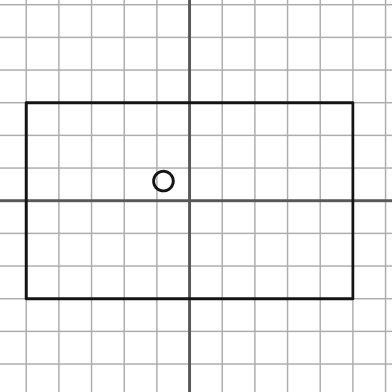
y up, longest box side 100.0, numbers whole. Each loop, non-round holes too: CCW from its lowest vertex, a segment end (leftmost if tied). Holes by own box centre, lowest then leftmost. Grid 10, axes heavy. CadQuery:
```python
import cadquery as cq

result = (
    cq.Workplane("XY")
    .moveTo(-50.0, -30.0)
    .lineTo(50.0, -30.0)
    .lineTo(50.0, 30.0)
    .lineTo(-50.0, 30.0)
    .close()
    .moveTo(-8.0, 6.0)
    .circle(3.0)
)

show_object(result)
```